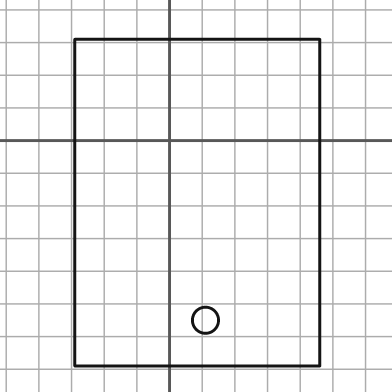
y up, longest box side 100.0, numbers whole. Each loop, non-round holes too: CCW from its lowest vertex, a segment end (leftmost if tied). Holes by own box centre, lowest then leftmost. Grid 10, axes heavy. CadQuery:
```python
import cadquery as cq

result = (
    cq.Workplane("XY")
    .moveTo(-29.0, -69.0)
    .lineTo(46.0, -69.0)
    .lineTo(46.0, 31.0)
    .lineTo(-29.0, 31.0)
    .close()
    .moveTo(11.0, -55.0)
    .circle(4.0)
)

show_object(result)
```